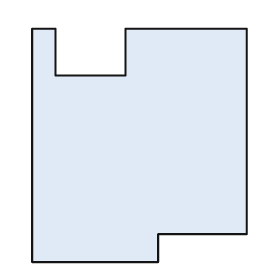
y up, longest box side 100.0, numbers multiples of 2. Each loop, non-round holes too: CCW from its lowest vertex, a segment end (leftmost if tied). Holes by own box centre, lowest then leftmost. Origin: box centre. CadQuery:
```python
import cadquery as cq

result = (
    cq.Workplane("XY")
    .moveTo(-46.0, -50.0)
    .lineTo(8.0, -50.0)
    .lineTo(8.0, -38.0)
    .lineTo(46.0, -38.0)
    .lineTo(46.0, 50.0)
    .lineTo(-6.0, 50.0)
    .lineTo(-6.0, 30.0)
    .lineTo(-36.0, 30.0)
    .lineTo(-36.0, 50.0)
    .lineTo(-46.0, 50.0)
    .close()
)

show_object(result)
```